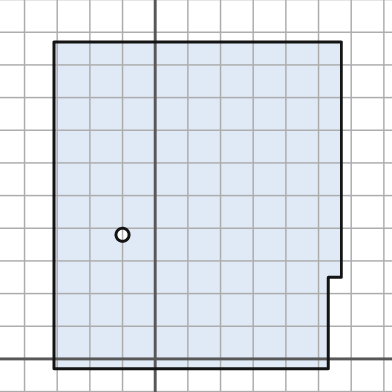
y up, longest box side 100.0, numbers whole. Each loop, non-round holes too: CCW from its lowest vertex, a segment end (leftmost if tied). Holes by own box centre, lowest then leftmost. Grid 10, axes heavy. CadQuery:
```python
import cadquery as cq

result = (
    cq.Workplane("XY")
    .moveTo(-31.0, -3.0)
    .lineTo(53.0, -3.0)
    .lineTo(53.0, 25.0)
    .lineTo(57.0, 25.0)
    .lineTo(57.0, 97.0)
    .lineTo(-31.0, 97.0)
    .close()
    .moveTo(-10.0, 38.0)
    .circle(2.0)
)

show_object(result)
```